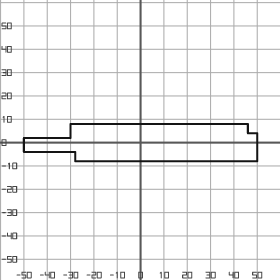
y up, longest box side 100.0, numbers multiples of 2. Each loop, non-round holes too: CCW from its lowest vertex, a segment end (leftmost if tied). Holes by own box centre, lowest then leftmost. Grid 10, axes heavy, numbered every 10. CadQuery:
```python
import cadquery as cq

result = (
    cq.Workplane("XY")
    .moveTo(-28.0, -8.0)
    .lineTo(50.0, -8.0)
    .lineTo(50.0, 4.0)
    .lineTo(46.0, 4.0)
    .lineTo(46.0, 8.0)
    .lineTo(-30.0, 8.0)
    .lineTo(-30.0, 2.0)
    .lineTo(-50.0, 2.0)
    .lineTo(-50.0, -4.0)
    .lineTo(-28.0, -4.0)
    .close()
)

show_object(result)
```